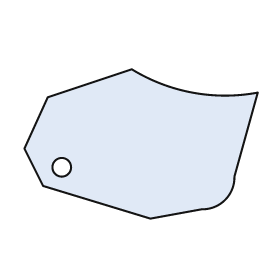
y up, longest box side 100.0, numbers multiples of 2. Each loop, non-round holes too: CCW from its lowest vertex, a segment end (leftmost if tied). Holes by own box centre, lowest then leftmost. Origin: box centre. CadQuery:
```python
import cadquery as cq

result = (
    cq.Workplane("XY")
    .moveTo(4.0, -32.0)
    .lineTo(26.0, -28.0)
    .threePointArc((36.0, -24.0), (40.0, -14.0))
    .lineTo(50.0, 22.0)
    .threePointArc((22.0, 22.0), (-4.0, 32.0))
    .lineTo(-40.0, 20.0)
    .lineTo(-50.0, -2.0)
    .lineTo(-42.0, -18.0)
    .close()
    .moveTo(-34.0, -10.0)
    .circle(4.0)
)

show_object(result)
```